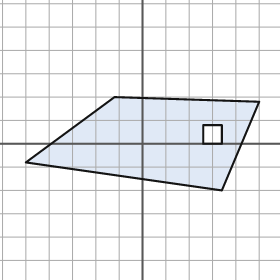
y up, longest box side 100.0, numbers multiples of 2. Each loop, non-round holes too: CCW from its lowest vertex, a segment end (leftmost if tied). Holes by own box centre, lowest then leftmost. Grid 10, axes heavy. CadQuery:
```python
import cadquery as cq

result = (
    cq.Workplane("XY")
    .moveTo(34.0, -20.0)
    .lineTo(50.0, 18.0)
    .lineTo(-12.0, 20.0)
    .lineTo(-50.0, -8.0)
    .close()
    .moveTo(26.0, 0.0)
    .lineTo(34.0, 0.0)
    .lineTo(34.0, 8.0)
    .lineTo(26.0, 8.0)
    .close()
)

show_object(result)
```